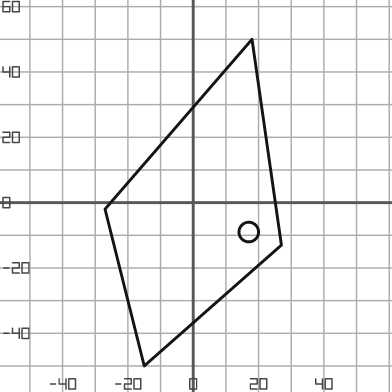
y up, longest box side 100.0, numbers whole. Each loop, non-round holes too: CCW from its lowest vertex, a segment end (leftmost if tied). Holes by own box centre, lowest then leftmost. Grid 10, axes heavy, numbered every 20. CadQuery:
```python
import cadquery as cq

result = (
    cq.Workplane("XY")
    .moveTo(-15.0, -50.0)
    .lineTo(27.0, -13.0)
    .lineTo(18.0, 50.0)
    .lineTo(-27.0, -2.0)
    .close()
    .moveTo(17.0, -9.0)
    .circle(3.0)
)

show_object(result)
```